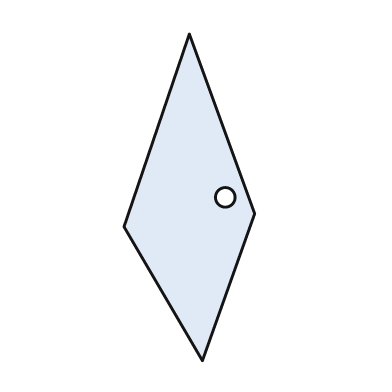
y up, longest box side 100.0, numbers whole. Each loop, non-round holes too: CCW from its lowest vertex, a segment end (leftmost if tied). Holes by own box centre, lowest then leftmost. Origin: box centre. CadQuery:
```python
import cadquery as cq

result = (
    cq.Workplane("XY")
    .moveTo(4.0, -50.0)
    .lineTo(20.0, -5.0)
    .lineTo(0.0, 50.0)
    .lineTo(-20.0, -9.0)
    .close()
    .moveTo(11.0, 0.0)
    .circle(3.0)
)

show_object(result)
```